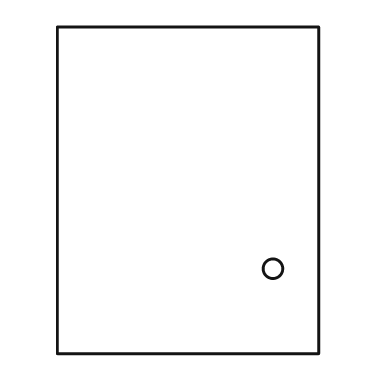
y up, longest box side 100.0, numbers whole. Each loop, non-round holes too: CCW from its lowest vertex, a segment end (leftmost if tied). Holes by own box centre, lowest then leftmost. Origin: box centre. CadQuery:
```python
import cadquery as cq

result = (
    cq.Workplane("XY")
    .moveTo(-40.0, -50.0)
    .lineTo(40.0, -50.0)
    .lineTo(40.0, 50.0)
    .lineTo(-40.0, 50.0)
    .close()
    .moveTo(26.0, -24.0)
    .circle(3.0)
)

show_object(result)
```